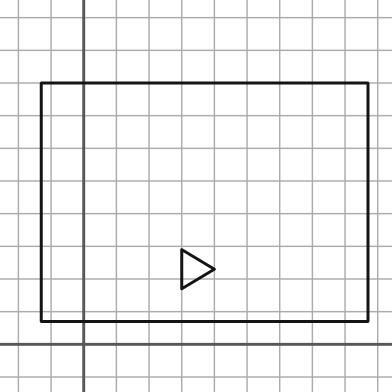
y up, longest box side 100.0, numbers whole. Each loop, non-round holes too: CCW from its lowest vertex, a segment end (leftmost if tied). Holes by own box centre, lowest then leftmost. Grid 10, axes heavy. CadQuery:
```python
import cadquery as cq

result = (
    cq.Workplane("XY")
    .moveTo(-13.0, 7.0)
    .lineTo(87.0, 7.0)
    .lineTo(87.0, 80.0)
    .lineTo(-13.0, 80.0)
    .close()
    .moveTo(30.0, 17.0)
    .lineTo(40.0, 23.0)
    .lineTo(30.0, 29.0)
    .close()
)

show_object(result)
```